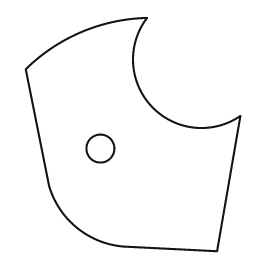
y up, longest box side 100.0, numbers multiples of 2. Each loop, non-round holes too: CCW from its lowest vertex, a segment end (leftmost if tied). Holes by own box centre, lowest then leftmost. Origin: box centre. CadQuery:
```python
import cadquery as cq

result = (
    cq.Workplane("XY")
    .moveTo(36.0, -50.0)
    .lineTo(46.0, 8.0)
    .threePointArc((8.0, 12.0), (6.0, 50.0))
    .threePointArc((-22.0, 44.0), (-46.0, 28.0))
    .lineTo(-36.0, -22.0)
    .threePointArc((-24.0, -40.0), (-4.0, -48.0))
    .close()
    .moveTo(-14.0, -6.0)
    .circle(6.0)
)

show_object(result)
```